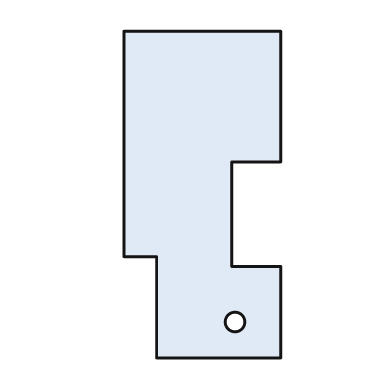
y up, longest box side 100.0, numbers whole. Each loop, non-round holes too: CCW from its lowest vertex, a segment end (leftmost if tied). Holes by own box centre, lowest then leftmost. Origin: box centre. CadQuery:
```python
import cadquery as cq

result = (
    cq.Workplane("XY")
    .moveTo(-14.0, -50.0)
    .lineTo(24.0, -50.0)
    .lineTo(24.0, -22.0)
    .lineTo(9.0, -22.0)
    .lineTo(9.0, 10.0)
    .lineTo(24.0, 10.0)
    .lineTo(24.0, 50.0)
    .lineTo(-24.0, 50.0)
    .lineTo(-24.0, -19.0)
    .lineTo(-14.0, -19.0)
    .close()
    .moveTo(10.0, -39.0)
    .circle(3.0)
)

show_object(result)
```